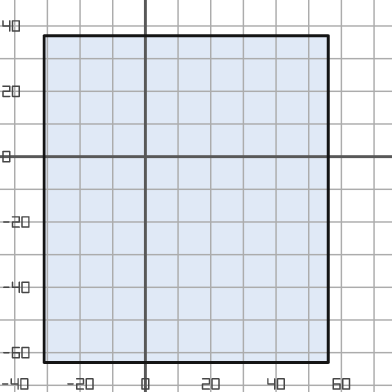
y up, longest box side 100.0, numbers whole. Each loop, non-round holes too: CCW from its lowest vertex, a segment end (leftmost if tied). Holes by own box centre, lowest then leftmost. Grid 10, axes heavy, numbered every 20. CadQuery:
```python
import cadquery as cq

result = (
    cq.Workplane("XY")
    .moveTo(-31.0, -63.0)
    .lineTo(56.0, -63.0)
    .lineTo(56.0, 37.0)
    .lineTo(-31.0, 37.0)
    .close()
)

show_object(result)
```